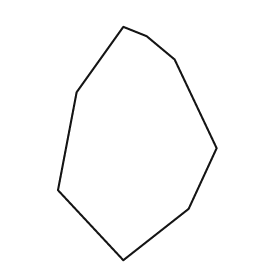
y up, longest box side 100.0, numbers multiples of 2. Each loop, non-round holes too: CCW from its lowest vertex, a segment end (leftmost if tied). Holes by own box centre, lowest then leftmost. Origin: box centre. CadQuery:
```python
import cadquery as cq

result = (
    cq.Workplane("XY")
    .moveTo(-6.0, -50.0)
    .lineTo(22.0, -28.0)
    .lineTo(34.0, -2.0)
    .lineTo(16.0, 36.0)
    .lineTo(4.0, 46.0)
    .lineTo(-6.0, 50.0)
    .lineTo(-26.0, 22.0)
    .lineTo(-34.0, -20.0)
    .close()
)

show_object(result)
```